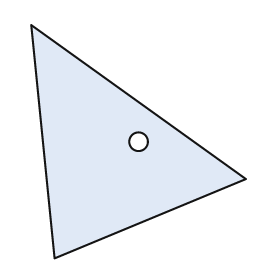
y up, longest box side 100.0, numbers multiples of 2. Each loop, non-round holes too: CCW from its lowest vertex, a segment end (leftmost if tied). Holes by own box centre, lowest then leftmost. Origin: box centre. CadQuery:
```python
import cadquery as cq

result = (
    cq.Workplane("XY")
    .moveTo(-36.0, -50.0)
    .lineTo(46.0, -16.0)
    .lineTo(-46.0, 50.0)
    .close()
    .moveTo(0.0, 0.0)
    .circle(4.0)
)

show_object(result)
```